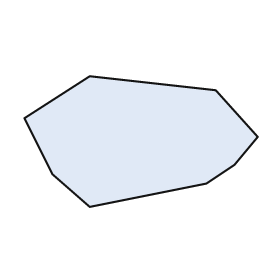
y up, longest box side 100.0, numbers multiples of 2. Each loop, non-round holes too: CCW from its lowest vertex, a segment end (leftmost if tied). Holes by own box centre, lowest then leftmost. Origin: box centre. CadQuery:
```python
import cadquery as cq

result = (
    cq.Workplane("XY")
    .moveTo(-22.0, -28.0)
    .lineTo(28.0, -18.0)
    .lineTo(40.0, -10.0)
    .lineTo(50.0, 2.0)
    .lineTo(32.0, 22.0)
    .lineTo(-22.0, 28.0)
    .lineTo(-50.0, 10.0)
    .lineTo(-38.0, -14.0)
    .close()
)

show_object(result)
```